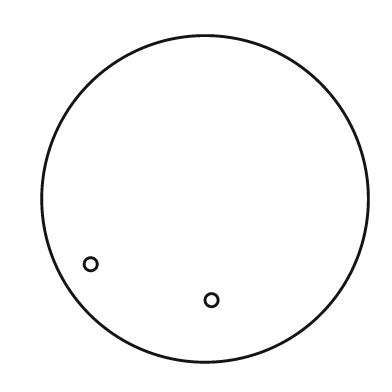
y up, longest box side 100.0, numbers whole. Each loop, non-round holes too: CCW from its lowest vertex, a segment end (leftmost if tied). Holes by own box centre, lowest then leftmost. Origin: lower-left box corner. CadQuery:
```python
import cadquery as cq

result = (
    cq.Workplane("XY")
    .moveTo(50.0, 50.0)
    .circle(50.0)
    .moveTo(52.0, 19.0)
    .circle(2.0)
    .moveTo(15.0, 30.0)
    .circle(2.0)
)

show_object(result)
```